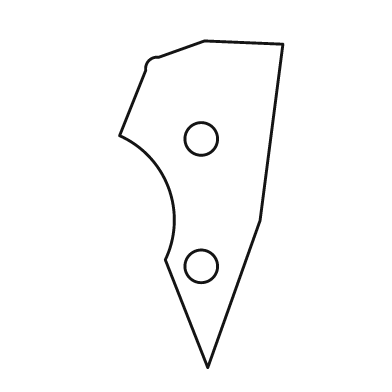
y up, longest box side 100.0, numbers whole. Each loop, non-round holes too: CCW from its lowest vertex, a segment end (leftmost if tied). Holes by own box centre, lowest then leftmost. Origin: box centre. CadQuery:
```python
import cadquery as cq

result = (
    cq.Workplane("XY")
    .moveTo(2.0, -50.0)
    .lineTo(18.0, -5.0)
    .lineTo(25.0, 49.0)
    .lineTo(1.0, 50.0)
    .lineTo(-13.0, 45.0)
    .threePointArc((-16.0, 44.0), (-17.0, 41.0))
    .lineTo(-25.0, 21.0)
    .threePointArc((-10.0, 5.0), (-11.0, -17.0))
    .close()
    .moveTo(0.0, -19.0)
    .circle(5.0)
    .moveTo(0.0, 20.0)
    .circle(5.0)
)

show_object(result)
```